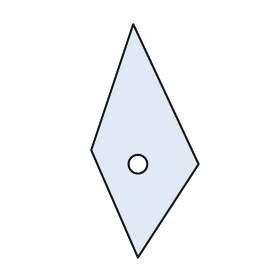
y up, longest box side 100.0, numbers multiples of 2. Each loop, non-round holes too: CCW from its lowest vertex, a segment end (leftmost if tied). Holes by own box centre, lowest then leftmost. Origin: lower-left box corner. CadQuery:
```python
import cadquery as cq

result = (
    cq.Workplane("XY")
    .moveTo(20.0, 0.0)
    .lineTo(46.0, 40.0)
    .lineTo(18.0, 100.0)
    .lineTo(0.0, 46.0)
    .close()
    .moveTo(20.0, 40.0)
    .circle(4.0)
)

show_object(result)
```